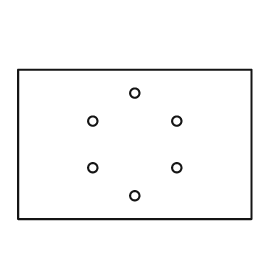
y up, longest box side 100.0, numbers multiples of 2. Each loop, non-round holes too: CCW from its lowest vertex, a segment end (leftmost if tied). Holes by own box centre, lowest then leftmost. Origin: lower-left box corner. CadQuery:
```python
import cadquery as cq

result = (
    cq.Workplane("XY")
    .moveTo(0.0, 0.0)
    .lineTo(100.0, 0.0)
    .lineTo(100.0, 64.0)
    .lineTo(0.0, 64.0)
    .close()
    .moveTo(50.0, 10.0)
    .circle(2.0)
    .moveTo(32.0, 22.0)
    .circle(2.0)
    .moveTo(68.0, 22.0)
    .circle(2.0)
    .moveTo(32.0, 42.0)
    .circle(2.0)
    .moveTo(68.0, 42.0)
    .circle(2.0)
    .moveTo(50.0, 54.0)
    .circle(2.0)
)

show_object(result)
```